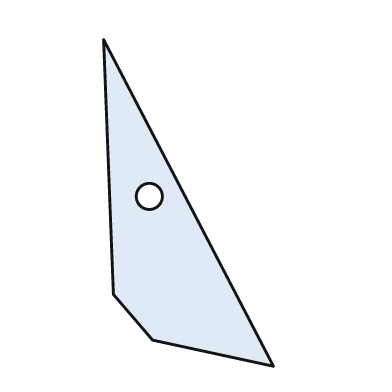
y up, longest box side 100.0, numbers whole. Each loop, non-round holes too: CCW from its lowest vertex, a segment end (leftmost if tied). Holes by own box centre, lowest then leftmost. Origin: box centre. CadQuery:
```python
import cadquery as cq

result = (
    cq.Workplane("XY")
    .moveTo(26.0, -50.0)
    .lineTo(-26.0, 50.0)
    .lineTo(-23.0, -28.0)
    .lineTo(-11.0, -42.0)
    .close()
    .moveTo(-12.0, 2.0)
    .circle(4.0)
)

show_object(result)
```